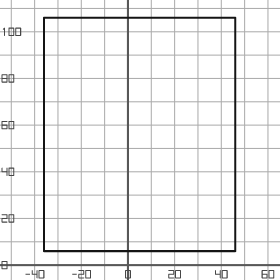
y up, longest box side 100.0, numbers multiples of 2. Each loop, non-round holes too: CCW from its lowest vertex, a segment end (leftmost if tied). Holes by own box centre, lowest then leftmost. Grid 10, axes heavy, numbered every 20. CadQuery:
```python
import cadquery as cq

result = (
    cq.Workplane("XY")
    .moveTo(-36.0, 6.0)
    .lineTo(46.0, 6.0)
    .lineTo(46.0, 106.0)
    .lineTo(-36.0, 106.0)
    .close()
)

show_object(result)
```